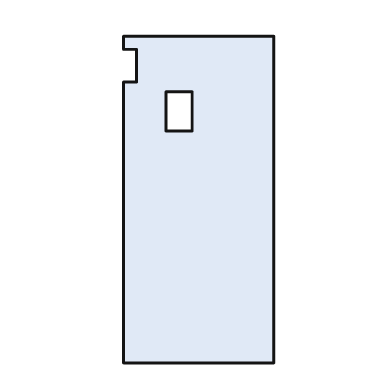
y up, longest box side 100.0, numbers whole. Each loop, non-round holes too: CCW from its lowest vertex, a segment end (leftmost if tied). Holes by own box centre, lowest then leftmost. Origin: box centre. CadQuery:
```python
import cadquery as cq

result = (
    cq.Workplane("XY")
    .moveTo(-23.0, -50.0)
    .lineTo(23.0, -50.0)
    .lineTo(23.0, 50.0)
    .lineTo(-23.0, 50.0)
    .lineTo(-23.0, 46.0)
    .lineTo(-19.0, 46.0)
    .lineTo(-19.0, 36.0)
    .lineTo(-23.0, 36.0)
    .close()
    .moveTo(-10.0, 21.0)
    .lineTo(-2.0, 21.0)
    .lineTo(-2.0, 33.0)
    .lineTo(-10.0, 33.0)
    .close()
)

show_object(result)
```